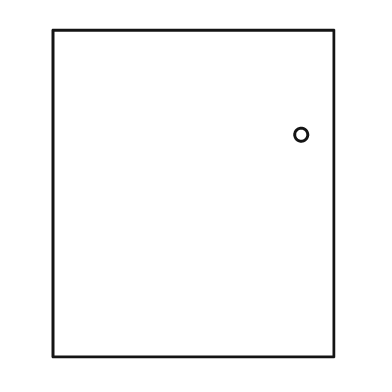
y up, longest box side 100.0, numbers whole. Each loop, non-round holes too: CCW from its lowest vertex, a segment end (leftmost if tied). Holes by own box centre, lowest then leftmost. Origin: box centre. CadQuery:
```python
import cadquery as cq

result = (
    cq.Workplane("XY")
    .moveTo(-43.0, -50.0)
    .lineTo(43.0, -50.0)
    .lineTo(43.0, 50.0)
    .lineTo(-43.0, 50.0)
    .close()
    .moveTo(33.0, 18.0)
    .circle(2.0)
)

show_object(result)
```